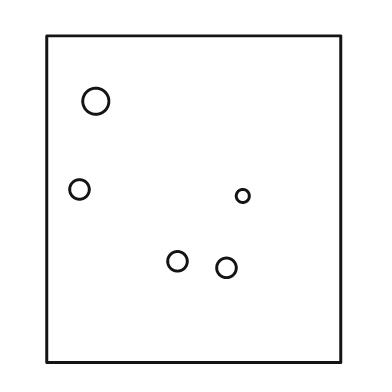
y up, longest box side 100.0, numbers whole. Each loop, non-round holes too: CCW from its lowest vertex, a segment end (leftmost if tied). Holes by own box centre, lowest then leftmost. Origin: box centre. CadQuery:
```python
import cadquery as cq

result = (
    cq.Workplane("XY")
    .moveTo(-45.0, -50.0)
    .lineTo(45.0, -50.0)
    .lineTo(45.0, 50.0)
    .lineTo(-45.0, 50.0)
    .close()
    .moveTo(10.0, -21.0)
    .circle(3.0)
    .moveTo(-5.0, -19.0)
    .circle(3.0)
    .moveTo(15.0, 1.0)
    .circle(2.0)
    .moveTo(-35.0, 3.0)
    .circle(3.0)
    .moveTo(-30.0, 30.0)
    .circle(4.0)
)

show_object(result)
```